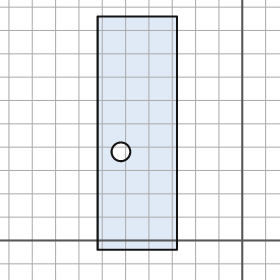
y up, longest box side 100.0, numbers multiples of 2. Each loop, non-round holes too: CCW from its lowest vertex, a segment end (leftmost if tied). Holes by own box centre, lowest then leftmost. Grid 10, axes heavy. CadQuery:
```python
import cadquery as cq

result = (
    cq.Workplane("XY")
    .moveTo(-62.0, -4.0)
    .lineTo(-28.0, -4.0)
    .lineTo(-28.0, 96.0)
    .lineTo(-62.0, 96.0)
    .close()
    .moveTo(-52.0, 38.0)
    .circle(4.0)
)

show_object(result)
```